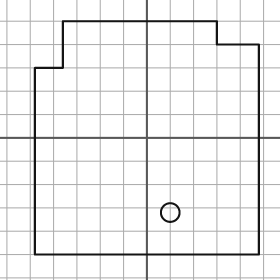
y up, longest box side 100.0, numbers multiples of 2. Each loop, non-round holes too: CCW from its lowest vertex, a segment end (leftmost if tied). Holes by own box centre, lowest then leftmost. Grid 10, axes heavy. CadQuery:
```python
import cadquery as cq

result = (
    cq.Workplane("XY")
    .moveTo(-48.0, -50.0)
    .lineTo(48.0, -50.0)
    .lineTo(48.0, 40.0)
    .lineTo(30.0, 40.0)
    .lineTo(30.0, 50.0)
    .lineTo(-36.0, 50.0)
    .lineTo(-36.0, 30.0)
    .lineTo(-48.0, 30.0)
    .close()
    .moveTo(10.0, -32.0)
    .circle(4.0)
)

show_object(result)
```